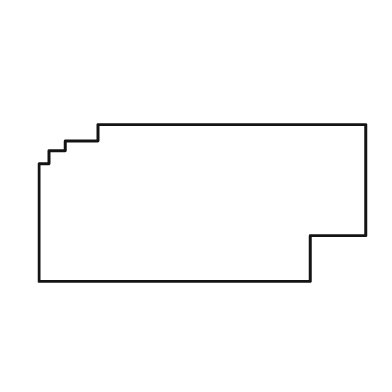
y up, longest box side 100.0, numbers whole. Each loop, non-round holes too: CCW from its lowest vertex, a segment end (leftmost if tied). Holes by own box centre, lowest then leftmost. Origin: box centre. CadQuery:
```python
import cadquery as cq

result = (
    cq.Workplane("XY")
    .moveTo(-50.0, -24.0)
    .lineTo(33.0, -24.0)
    .lineTo(33.0, -10.0)
    .lineTo(50.0, -10.0)
    .lineTo(50.0, 24.0)
    .lineTo(-32.0, 24.0)
    .lineTo(-32.0, 19.0)
    .lineTo(-42.0, 19.0)
    .lineTo(-42.0, 16.0)
    .lineTo(-47.0, 16.0)
    .lineTo(-47.0, 12.0)
    .lineTo(-50.0, 12.0)
    .close()
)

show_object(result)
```